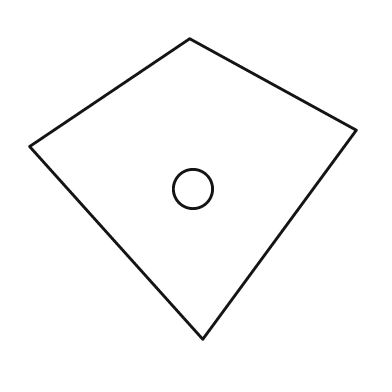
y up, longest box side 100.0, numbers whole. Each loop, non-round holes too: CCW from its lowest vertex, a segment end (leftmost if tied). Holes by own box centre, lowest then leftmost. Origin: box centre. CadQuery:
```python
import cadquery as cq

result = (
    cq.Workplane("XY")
    .moveTo(3.0, -46.0)
    .lineTo(50.0, 18.0)
    .lineTo(-1.0, 46.0)
    .lineTo(-50.0, 13.0)
    .close()
    .moveTo(0.0, 0.0)
    .circle(6.0)
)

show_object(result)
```